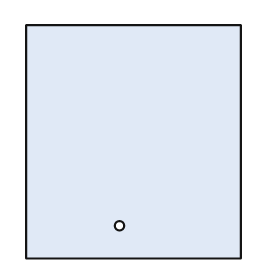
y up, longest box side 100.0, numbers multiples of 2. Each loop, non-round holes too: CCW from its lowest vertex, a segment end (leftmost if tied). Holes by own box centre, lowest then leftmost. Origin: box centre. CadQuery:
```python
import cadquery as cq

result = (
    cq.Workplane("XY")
    .moveTo(-46.0, -50.0)
    .lineTo(46.0, -50.0)
    .lineTo(46.0, 50.0)
    .lineTo(-46.0, 50.0)
    .close()
    .moveTo(-6.0, -36.0)
    .circle(2.0)
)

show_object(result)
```